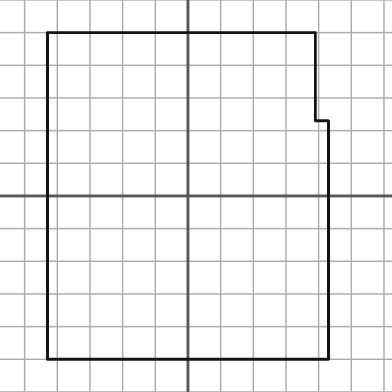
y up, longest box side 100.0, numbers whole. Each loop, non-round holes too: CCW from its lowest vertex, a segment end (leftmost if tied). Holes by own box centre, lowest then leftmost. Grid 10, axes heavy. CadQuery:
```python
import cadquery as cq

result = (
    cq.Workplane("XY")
    .moveTo(-43.0, -50.0)
    .lineTo(43.0, -50.0)
    .lineTo(43.0, 23.0)
    .lineTo(39.0, 23.0)
    .lineTo(39.0, 50.0)
    .lineTo(-43.0, 50.0)
    .close()
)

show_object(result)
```